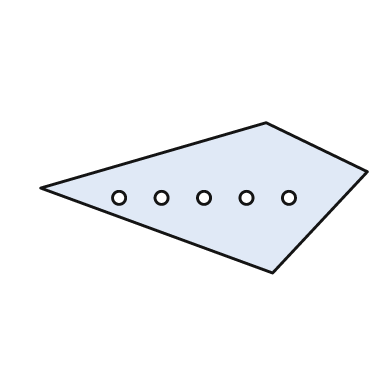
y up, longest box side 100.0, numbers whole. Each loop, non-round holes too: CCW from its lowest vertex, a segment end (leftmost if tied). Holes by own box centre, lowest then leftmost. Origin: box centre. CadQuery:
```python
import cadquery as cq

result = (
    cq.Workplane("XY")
    .moveTo(21.0, -23.0)
    .lineTo(50.0, 8.0)
    .lineTo(19.0, 23.0)
    .lineTo(-50.0, 3.0)
    .close()
    .moveTo(-26.0, 0.0)
    .circle(2.0)
    .moveTo(-13.0, 0.0)
    .circle(2.0)
    .moveTo(0.0, 0.0)
    .circle(2.0)
    .moveTo(13.0, 0.0)
    .circle(2.0)
    .moveTo(26.0, 0.0)
    .circle(2.0)
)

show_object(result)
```